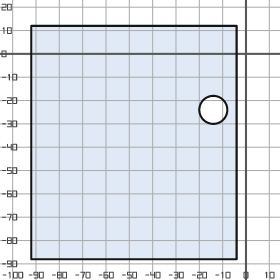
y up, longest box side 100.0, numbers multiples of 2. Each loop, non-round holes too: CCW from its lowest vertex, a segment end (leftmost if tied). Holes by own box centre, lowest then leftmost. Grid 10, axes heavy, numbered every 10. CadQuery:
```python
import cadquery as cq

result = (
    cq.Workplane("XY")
    .moveTo(-92.0, -88.0)
    .lineTo(-4.0, -88.0)
    .lineTo(-4.0, 12.0)
    .lineTo(-92.0, 12.0)
    .close()
    .moveTo(-14.0, -24.0)
    .circle(6.0)
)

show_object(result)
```